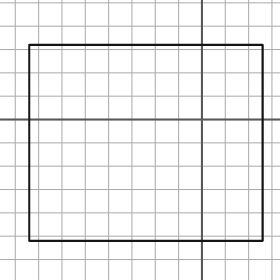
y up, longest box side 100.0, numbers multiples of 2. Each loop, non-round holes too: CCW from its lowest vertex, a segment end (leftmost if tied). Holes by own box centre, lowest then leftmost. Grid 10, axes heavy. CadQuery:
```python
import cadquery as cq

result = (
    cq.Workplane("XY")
    .moveTo(-74.0, -52.0)
    .lineTo(26.0, -52.0)
    .lineTo(26.0, 32.0)
    .lineTo(-74.0, 32.0)
    .close()
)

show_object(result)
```